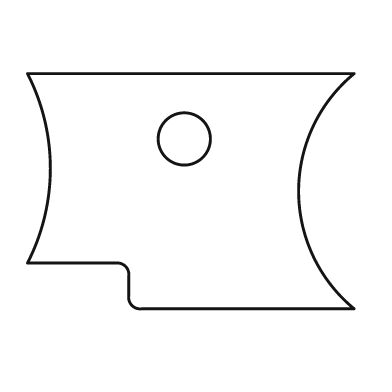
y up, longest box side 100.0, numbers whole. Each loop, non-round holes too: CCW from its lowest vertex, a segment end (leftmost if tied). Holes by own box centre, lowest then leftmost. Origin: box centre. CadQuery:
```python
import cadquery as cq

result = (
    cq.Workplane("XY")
    .moveTo(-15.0, -36.0)
    .lineTo(50.0, -36.0)
    .threePointArc((33.0, 0.0), (50.0, 36.0))
    .lineTo(-50.0, 36.0)
    .threePointArc((-43.0, 7.0), (-50.0, -22.0))
    .lineTo(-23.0, -22.0)
    .threePointArc((-20.0, -23.0), (-19.0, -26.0))
    .lineTo(-19.0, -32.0)
    .threePointArc((-18.0, -35.0), (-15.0, -36.0))
    .close()
    .moveTo(-2.0, 16.0)
    .circle(8.0)
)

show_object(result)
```